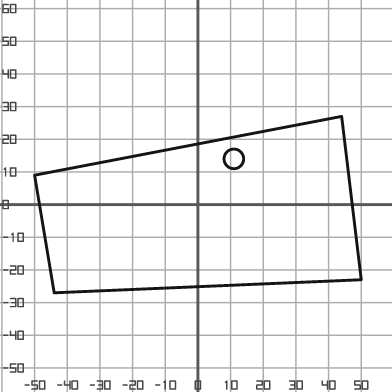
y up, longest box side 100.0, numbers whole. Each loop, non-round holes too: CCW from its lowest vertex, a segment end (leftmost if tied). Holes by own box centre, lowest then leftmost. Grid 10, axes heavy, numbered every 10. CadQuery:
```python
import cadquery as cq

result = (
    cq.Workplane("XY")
    .moveTo(-44.0, -27.0)
    .lineTo(50.0, -23.0)
    .lineTo(44.0, 27.0)
    .lineTo(-50.0, 9.0)
    .close()
    .moveTo(11.0, 14.0)
    .circle(3.0)
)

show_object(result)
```